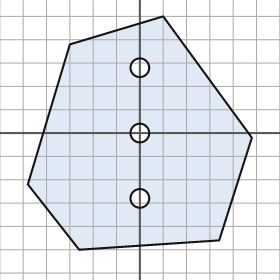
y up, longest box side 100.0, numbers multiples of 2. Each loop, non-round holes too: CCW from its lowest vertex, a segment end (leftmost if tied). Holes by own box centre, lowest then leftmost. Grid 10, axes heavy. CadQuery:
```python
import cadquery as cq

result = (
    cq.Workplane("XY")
    .moveTo(-26.0, -50.0)
    .lineTo(34.0, -46.0)
    .lineTo(48.0, -2.0)
    .lineTo(10.0, 50.0)
    .lineTo(-30.0, 38.0)
    .lineTo(-48.0, -22.0)
    .close()
    .moveTo(0.0, -28.0)
    .circle(4.0)
    .moveTo(0.0, 0.0)
    .circle(4.0)
    .moveTo(0.0, 28.0)
    .circle(4.0)
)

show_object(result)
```